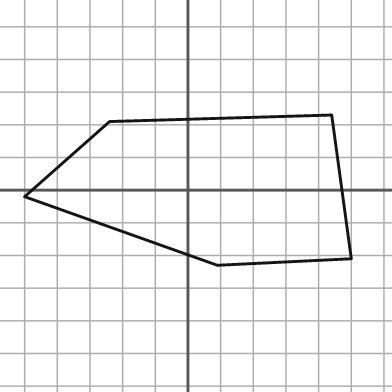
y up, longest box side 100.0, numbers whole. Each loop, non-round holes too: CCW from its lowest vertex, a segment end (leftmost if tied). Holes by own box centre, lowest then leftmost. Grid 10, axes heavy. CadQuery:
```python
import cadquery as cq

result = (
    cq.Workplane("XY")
    .moveTo(9.0, -23.0)
    .lineTo(50.0, -21.0)
    .lineTo(44.0, 23.0)
    .lineTo(-24.0, 21.0)
    .lineTo(-50.0, -2.0)
    .close()
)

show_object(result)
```